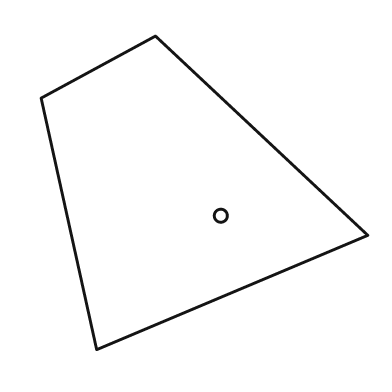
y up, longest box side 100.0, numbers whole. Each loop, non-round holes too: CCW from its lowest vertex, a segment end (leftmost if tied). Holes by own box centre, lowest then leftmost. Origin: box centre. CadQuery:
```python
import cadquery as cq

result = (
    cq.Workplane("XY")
    .moveTo(-33.0, -48.0)
    .lineTo(50.0, -13.0)
    .lineTo(-15.0, 48.0)
    .lineTo(-50.0, 29.0)
    .close()
    .moveTo(5.0, -7.0)
    .circle(2.0)
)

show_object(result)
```